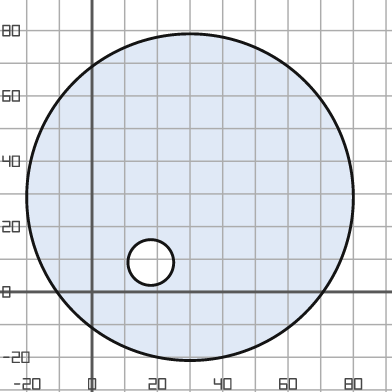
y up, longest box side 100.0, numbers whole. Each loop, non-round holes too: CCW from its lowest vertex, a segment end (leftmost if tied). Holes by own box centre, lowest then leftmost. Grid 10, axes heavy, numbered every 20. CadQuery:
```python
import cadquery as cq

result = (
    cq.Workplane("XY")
    .moveTo(30.0, 29.0)
    .circle(50.0)
    .moveTo(18.0, 9.0)
    .circle(7.0)
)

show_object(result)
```